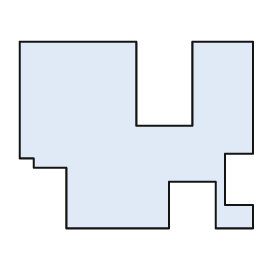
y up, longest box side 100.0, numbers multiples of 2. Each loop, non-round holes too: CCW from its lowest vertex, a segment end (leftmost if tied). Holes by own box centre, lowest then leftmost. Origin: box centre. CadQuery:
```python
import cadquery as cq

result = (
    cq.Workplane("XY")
    .moveTo(-30.0, -40.0)
    .lineTo(14.0, -40.0)
    .lineTo(14.0, -20.0)
    .lineTo(34.0, -20.0)
    .lineTo(34.0, -40.0)
    .lineTo(50.0, -40.0)
    .lineTo(50.0, -30.0)
    .lineTo(38.0, -30.0)
    .lineTo(38.0, -8.0)
    .lineTo(50.0, -8.0)
    .lineTo(50.0, 40.0)
    .lineTo(24.0, 40.0)
    .lineTo(24.0, 4.0)
    .lineTo(0.0, 4.0)
    .lineTo(0.0, 40.0)
    .lineTo(-50.0, 40.0)
    .lineTo(-50.0, -10.0)
    .lineTo(-44.0, -10.0)
    .lineTo(-44.0, -14.0)
    .lineTo(-30.0, -14.0)
    .close()
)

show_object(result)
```